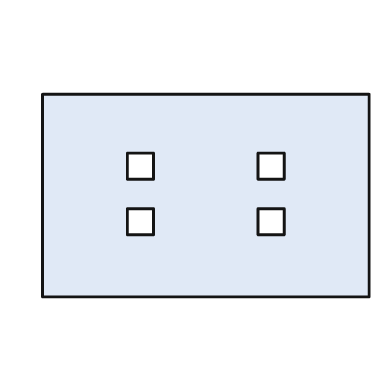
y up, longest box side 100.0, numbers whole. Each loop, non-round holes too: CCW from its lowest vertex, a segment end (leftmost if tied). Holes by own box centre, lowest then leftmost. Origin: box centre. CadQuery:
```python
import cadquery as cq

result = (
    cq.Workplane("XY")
    .moveTo(-50.0, -31.0)
    .lineTo(50.0, -31.0)
    .lineTo(50.0, 31.0)
    .lineTo(-50.0, 31.0)
    .close()
    .moveTo(-24.0, -12.0)
    .lineTo(-16.0, -12.0)
    .lineTo(-16.0, -4.0)
    .lineTo(-24.0, -4.0)
    .close()
    .moveTo(16.0, -12.0)
    .lineTo(24.0, -12.0)
    .lineTo(24.0, -4.0)
    .lineTo(16.0, -4.0)
    .close()
    .moveTo(-24.0, 5.0)
    .lineTo(-16.0, 5.0)
    .lineTo(-16.0, 13.0)
    .lineTo(-24.0, 13.0)
    .close()
    .moveTo(16.0, 5.0)
    .lineTo(24.0, 5.0)
    .lineTo(24.0, 13.0)
    .lineTo(16.0, 13.0)
    .close()
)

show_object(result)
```